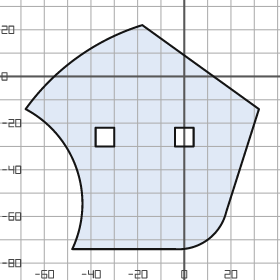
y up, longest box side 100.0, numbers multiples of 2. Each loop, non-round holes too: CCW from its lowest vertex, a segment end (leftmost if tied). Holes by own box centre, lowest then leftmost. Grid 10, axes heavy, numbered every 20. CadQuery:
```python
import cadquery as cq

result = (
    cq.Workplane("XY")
    .moveTo(-48.0, -74.0)
    .lineTo(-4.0, -74.0)
    .threePointArc((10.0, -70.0), (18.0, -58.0))
    .lineTo(32.0, -14.0)
    .lineTo(-18.0, 22.0)
    .threePointArc((-46.0, 8.0), (-68.0, -14.0))
    .threePointArc((-46.0, -40.0), (-48.0, -74.0))
    .close()
    .moveTo(-38.0, -30.0)
    .lineTo(-30.0, -30.0)
    .lineTo(-30.0, -22.0)
    .lineTo(-38.0, -22.0)
    .close()
    .moveTo(-4.0, -30.0)
    .lineTo(4.0, -30.0)
    .lineTo(4.0, -22.0)
    .lineTo(-4.0, -22.0)
    .close()
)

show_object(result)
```